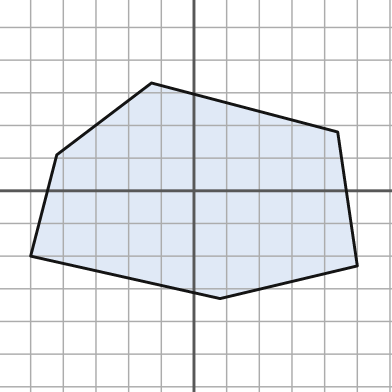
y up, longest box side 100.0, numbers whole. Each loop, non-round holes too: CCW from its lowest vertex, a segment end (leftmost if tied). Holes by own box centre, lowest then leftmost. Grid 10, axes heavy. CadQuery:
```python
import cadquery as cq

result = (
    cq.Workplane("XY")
    .moveTo(8.0, -33.0)
    .lineTo(50.0, -23.0)
    .lineTo(44.0, 18.0)
    .lineTo(-13.0, 33.0)
    .lineTo(-42.0, 11.0)
    .lineTo(-50.0, -20.0)
    .close()
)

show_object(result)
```